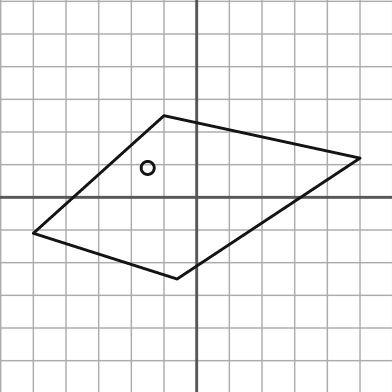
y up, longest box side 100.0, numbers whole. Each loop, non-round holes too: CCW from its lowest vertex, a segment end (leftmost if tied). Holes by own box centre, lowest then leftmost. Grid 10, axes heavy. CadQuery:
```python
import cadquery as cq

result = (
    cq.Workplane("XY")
    .moveTo(-6.0, -25.0)
    .lineTo(50.0, 12.0)
    .lineTo(-10.0, 25.0)
    .lineTo(-50.0, -11.0)
    .close()
    .moveTo(-15.0, 9.0)
    .circle(2.0)
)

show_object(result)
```